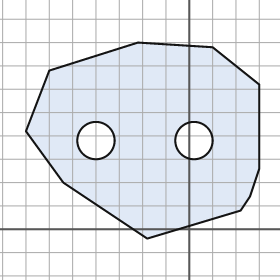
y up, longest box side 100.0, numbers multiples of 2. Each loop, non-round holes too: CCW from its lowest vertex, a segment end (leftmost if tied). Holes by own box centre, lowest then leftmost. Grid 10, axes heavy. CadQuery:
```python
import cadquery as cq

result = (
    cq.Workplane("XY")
    .moveTo(-18.0, -4.0)
    .lineTo(22.0, 8.0)
    .lineTo(26.0, 14.0)
    .lineTo(30.0, 26.0)
    .lineTo(30.0, 62.0)
    .lineTo(10.0, 78.0)
    .lineTo(-22.0, 80.0)
    .lineTo(-60.0, 68.0)
    .lineTo(-70.0, 42.0)
    .lineTo(-54.0, 20.0)
    .close()
    .moveTo(-40.0, 38.0)
    .circle(8.0)
    .moveTo(2.0, 38.0)
    .circle(8.0)
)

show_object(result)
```